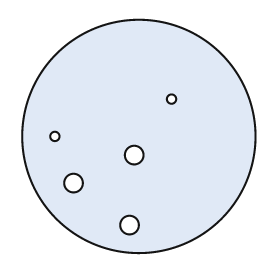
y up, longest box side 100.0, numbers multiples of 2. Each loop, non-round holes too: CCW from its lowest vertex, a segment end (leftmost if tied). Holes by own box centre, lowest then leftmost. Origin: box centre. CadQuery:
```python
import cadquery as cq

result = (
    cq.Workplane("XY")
    .moveTo(0.0, 0.0)
    .circle(50.0)
    .moveTo(-4.0, -38.0)
    .circle(4.0)
    .moveTo(-28.0, -20.0)
    .circle(4.0)
    .moveTo(-2.0, -8.0)
    .circle(4.0)
    .moveTo(-36.0, 0.0)
    .circle(2.0)
    .moveTo(14.0, 16.0)
    .circle(2.0)
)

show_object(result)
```